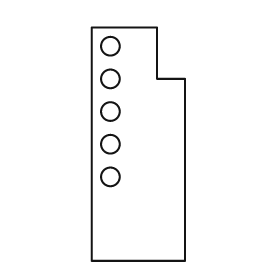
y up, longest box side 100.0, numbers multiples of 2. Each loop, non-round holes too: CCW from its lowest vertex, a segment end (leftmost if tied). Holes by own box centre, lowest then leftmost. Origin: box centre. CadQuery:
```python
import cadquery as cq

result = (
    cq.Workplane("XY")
    .moveTo(-20.0, -50.0)
    .lineTo(20.0, -50.0)
    .lineTo(20.0, 28.0)
    .lineTo(8.0, 28.0)
    .lineTo(8.0, 50.0)
    .lineTo(-20.0, 50.0)
    .close()
    .moveTo(-12.0, -14.0)
    .circle(4.0)
    .moveTo(-12.0, 0.0)
    .circle(4.0)
    .moveTo(-12.0, 14.0)
    .circle(4.0)
    .moveTo(-12.0, 28.0)
    .circle(4.0)
    .moveTo(-12.0, 42.0)
    .circle(4.0)
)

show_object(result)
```